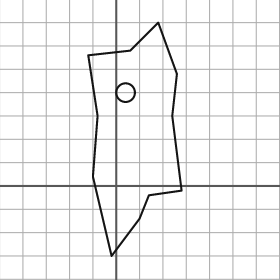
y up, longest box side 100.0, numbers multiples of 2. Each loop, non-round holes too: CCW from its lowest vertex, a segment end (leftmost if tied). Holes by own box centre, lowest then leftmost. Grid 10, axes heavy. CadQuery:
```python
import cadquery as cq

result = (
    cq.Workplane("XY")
    .moveTo(-2.0, -30.0)
    .lineTo(10.0, -14.0)
    .lineTo(14.0, -4.0)
    .lineTo(28.0, -2.0)
    .lineTo(24.0, 30.0)
    .lineTo(26.0, 48.0)
    .lineTo(18.0, 70.0)
    .lineTo(6.0, 58.0)
    .lineTo(-12.0, 56.0)
    .lineTo(-8.0, 30.0)
    .lineTo(-10.0, 4.0)
    .close()
    .moveTo(4.0, 40.0)
    .circle(4.0)
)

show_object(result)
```